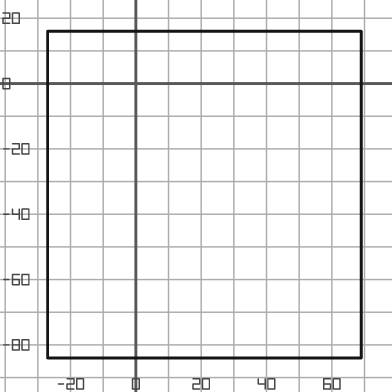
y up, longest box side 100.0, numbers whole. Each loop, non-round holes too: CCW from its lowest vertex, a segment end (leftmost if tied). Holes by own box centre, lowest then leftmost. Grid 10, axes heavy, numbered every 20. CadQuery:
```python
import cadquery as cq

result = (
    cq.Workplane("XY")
    .moveTo(-27.0, -84.0)
    .lineTo(69.0, -84.0)
    .lineTo(69.0, 16.0)
    .lineTo(-27.0, 16.0)
    .close()
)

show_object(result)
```